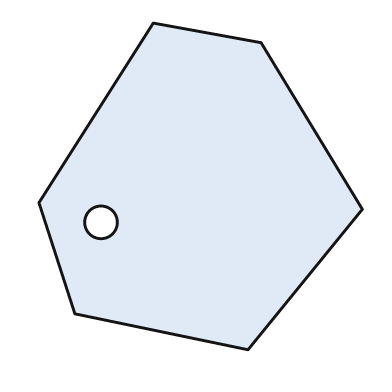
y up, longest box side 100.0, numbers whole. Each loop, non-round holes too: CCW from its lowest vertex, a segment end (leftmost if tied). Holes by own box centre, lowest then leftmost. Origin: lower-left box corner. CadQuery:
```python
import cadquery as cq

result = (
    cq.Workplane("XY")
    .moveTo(64.0, 0.0)
    .lineTo(99.0, 43.0)
    .lineTo(68.0, 94.0)
    .lineTo(35.0, 100.0)
    .lineTo(0.0, 45.0)
    .lineTo(11.0, 11.0)
    .close()
    .moveTo(19.0, 39.0)
    .circle(5.0)
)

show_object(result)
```